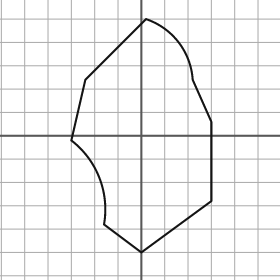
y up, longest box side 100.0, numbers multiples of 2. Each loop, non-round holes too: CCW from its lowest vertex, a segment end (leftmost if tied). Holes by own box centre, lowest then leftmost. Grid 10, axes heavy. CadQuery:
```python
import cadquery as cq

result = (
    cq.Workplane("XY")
    .moveTo(0.0, -50.0)
    .lineTo(30.0, -28.0)
    .lineTo(30.0, 6.0)
    .lineTo(22.0, 24.0)
    .threePointArc((16.0, 40.0), (2.0, 50.0))
    .lineTo(-24.0, 24.0)
    .lineTo(-30.0, -2.0)
    .threePointArc((-18.0, -18.0), (-16.0, -38.0))
    .close()
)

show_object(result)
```